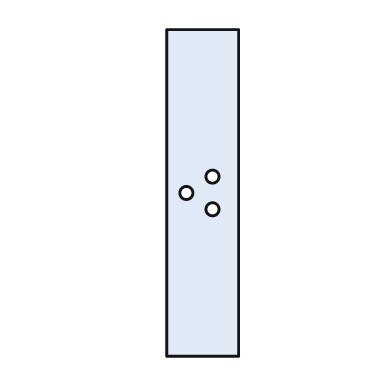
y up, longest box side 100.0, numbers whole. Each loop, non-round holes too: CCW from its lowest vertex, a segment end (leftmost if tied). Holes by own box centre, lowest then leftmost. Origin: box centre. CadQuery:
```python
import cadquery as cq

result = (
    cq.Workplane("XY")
    .moveTo(-11.0, -50.0)
    .lineTo(11.0, -50.0)
    .lineTo(11.0, 50.0)
    .lineTo(-11.0, 50.0)
    .close()
    .moveTo(3.0, -5.0)
    .circle(2.0)
    .moveTo(-5.0, 0.0)
    .circle(2.0)
    .moveTo(3.0, 5.0)
    .circle(2.0)
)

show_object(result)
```